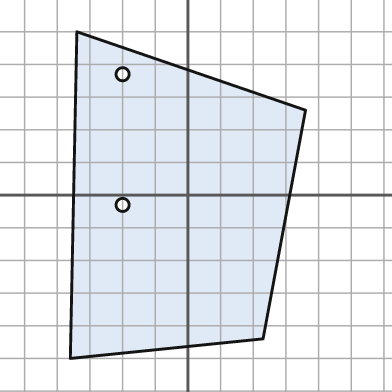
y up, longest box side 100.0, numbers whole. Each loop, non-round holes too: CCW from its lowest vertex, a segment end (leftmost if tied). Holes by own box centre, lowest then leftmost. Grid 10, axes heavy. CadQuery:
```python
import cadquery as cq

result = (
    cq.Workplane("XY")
    .moveTo(-36.0, -50.0)
    .lineTo(23.0, -44.0)
    .lineTo(36.0, 26.0)
    .lineTo(-34.0, 50.0)
    .close()
    .moveTo(-20.0, -3.0)
    .circle(2.0)
    .moveTo(-20.0, 37.0)
    .circle(2.0)
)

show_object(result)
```